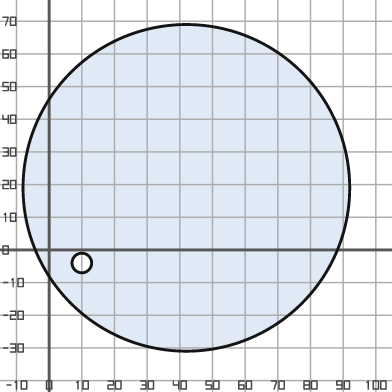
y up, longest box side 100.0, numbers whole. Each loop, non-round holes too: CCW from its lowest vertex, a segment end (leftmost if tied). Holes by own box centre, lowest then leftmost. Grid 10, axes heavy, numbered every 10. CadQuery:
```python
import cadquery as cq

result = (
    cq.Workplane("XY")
    .moveTo(42.0, 19.0)
    .circle(50.0)
    .moveTo(10.0, -4.0)
    .circle(3.0)
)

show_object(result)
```